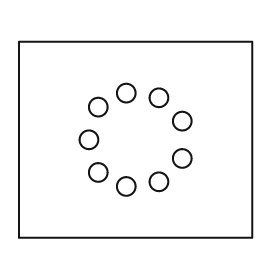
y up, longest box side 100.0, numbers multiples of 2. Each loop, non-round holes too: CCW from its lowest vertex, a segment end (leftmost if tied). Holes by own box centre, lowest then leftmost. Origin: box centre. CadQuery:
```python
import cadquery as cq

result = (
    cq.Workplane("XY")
    .moveTo(-50.0, -42.0)
    .lineTo(50.0, -42.0)
    .lineTo(50.0, 42.0)
    .lineTo(-50.0, 42.0)
    .close()
    .moveTo(-4.0, -20.0)
    .circle(4.0)
    .moveTo(10.0, -18.0)
    .circle(4.0)
    .moveTo(-16.0, -14.0)
    .circle(4.0)
    .moveTo(20.0, -8.0)
    .circle(4.0)
    .moveTo(-20.0, 0.0)
    .circle(4.0)
    .moveTo(20.0, 8.0)
    .circle(4.0)
    .moveTo(-16.0, 14.0)
    .circle(4.0)
    .moveTo(10.0, 18.0)
    .circle(4.0)
    .moveTo(-4.0, 20.0)
    .circle(4.0)
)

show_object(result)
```